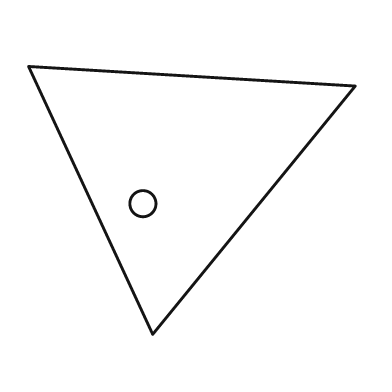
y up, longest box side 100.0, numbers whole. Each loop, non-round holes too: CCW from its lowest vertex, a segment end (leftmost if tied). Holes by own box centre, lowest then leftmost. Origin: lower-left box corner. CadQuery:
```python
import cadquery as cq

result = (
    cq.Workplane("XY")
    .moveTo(38.0, 0.0)
    .lineTo(100.0, 76.0)
    .lineTo(0.0, 82.0)
    .close()
    .moveTo(35.0, 40.0)
    .circle(4.0)
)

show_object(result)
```